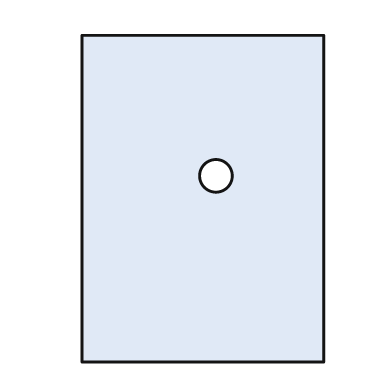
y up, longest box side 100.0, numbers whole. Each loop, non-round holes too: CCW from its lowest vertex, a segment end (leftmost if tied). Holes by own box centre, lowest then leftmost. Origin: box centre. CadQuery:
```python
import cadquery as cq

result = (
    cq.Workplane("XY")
    .moveTo(-37.0, -50.0)
    .lineTo(37.0, -50.0)
    .lineTo(37.0, 50.0)
    .lineTo(-37.0, 50.0)
    .close()
    .moveTo(4.0, 7.0)
    .circle(5.0)
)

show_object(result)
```